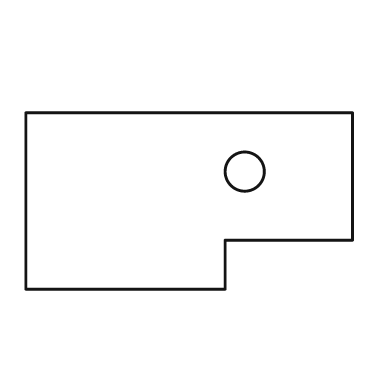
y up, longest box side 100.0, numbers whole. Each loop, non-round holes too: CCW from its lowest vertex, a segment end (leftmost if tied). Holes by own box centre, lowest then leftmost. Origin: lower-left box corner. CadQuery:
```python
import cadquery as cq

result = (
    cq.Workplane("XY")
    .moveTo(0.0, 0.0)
    .lineTo(61.0, 0.0)
    .lineTo(61.0, 15.0)
    .lineTo(100.0, 15.0)
    .lineTo(100.0, 54.0)
    .lineTo(0.0, 54.0)
    .close()
    .moveTo(67.0, 36.0)
    .circle(6.0)
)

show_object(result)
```